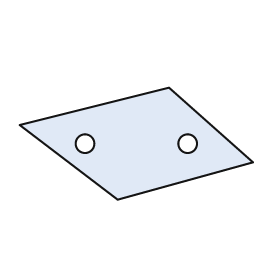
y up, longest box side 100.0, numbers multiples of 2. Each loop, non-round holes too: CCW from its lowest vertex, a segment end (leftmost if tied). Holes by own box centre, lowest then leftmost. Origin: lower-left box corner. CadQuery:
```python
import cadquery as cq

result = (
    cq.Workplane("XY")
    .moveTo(42.0, 0.0)
    .lineTo(100.0, 16.0)
    .lineTo(64.0, 48.0)
    .lineTo(0.0, 32.0)
    .close()
    .moveTo(28.0, 24.0)
    .circle(4.0)
    .moveTo(72.0, 24.0)
    .circle(4.0)
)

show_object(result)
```